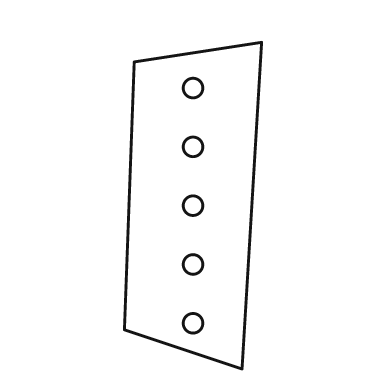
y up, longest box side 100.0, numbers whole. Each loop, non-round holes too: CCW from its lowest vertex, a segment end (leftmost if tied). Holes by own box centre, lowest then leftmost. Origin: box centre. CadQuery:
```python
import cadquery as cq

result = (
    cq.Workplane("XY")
    .moveTo(15.0, -50.0)
    .lineTo(21.0, 50.0)
    .lineTo(-18.0, 44.0)
    .lineTo(-21.0, -38.0)
    .close()
    .moveTo(0.0, -36.0)
    .circle(3.0)
    .moveTo(0.0, -18.0)
    .circle(3.0)
    .moveTo(0.0, 0.0)
    .circle(3.0)
    .moveTo(0.0, 18.0)
    .circle(3.0)
    .moveTo(0.0, 36.0)
    .circle(3.0)
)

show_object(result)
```